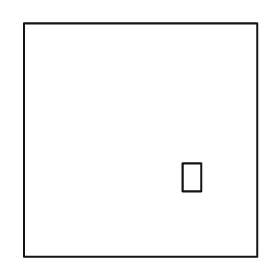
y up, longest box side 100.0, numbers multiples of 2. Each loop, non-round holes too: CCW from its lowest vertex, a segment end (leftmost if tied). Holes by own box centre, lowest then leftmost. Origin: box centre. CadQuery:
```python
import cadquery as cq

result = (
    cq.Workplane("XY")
    .moveTo(-50.0, -50.0)
    .lineTo(50.0, -50.0)
    .lineTo(50.0, 50.0)
    .lineTo(-50.0, 50.0)
    .close()
    .moveTo(18.0, -22.0)
    .lineTo(26.0, -22.0)
    .lineTo(26.0, -10.0)
    .lineTo(18.0, -10.0)
    .close()
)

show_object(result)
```